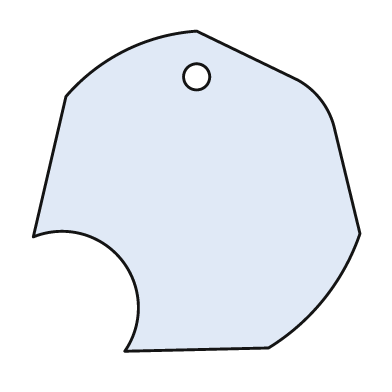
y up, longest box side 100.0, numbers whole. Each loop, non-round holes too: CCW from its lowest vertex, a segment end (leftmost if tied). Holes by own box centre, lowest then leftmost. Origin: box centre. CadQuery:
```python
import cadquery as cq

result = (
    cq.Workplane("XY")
    .moveTo(-22.0, -49.0)
    .lineTo(22.0, -48.0)
    .threePointArc((39.0, -33.0), (50.0, -13.0))
    .lineTo(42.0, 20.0)
    .threePointArc((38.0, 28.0), (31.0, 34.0))
    .lineTo(0.0, 49.0)
    .threePointArc((-22.0, 43.0), (-40.0, 29.0))
    .lineTo(-50.0, -14.0)
    .threePointArc((-23.0, -21.0), (-22.0, -49.0))
    .close()
    .moveTo(0.0, 35.0)
    .circle(4.0)
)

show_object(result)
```